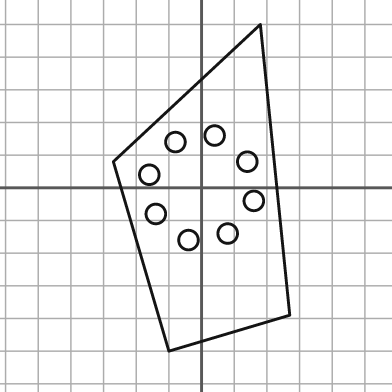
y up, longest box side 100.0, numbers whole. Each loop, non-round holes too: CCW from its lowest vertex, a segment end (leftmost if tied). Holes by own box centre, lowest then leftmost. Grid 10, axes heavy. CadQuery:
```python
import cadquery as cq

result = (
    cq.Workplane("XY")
    .moveTo(-10.0, -50.0)
    .lineTo(27.0, -39.0)
    .lineTo(18.0, 50.0)
    .lineTo(-27.0, 8.0)
    .close()
    .moveTo(-4.0, -16.0)
    .circle(3.0)
    .moveTo(8.0, -14.0)
    .circle(3.0)
    .moveTo(-14.0, -8.0)
    .circle(3.0)
    .moveTo(16.0, -4.0)
    .circle(3.0)
    .moveTo(-16.0, 4.0)
    .circle(3.0)
    .moveTo(14.0, 8.0)
    .circle(3.0)
    .moveTo(-8.0, 14.0)
    .circle(3.0)
    .moveTo(4.0, 16.0)
    .circle(3.0)
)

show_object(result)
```